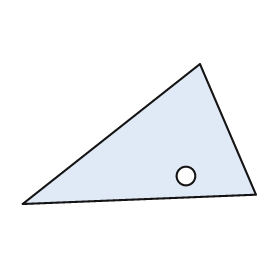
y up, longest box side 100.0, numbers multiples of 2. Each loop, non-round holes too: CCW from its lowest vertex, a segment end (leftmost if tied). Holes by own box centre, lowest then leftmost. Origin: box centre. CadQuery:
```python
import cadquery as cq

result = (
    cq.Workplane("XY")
    .moveTo(-50.0, -30.0)
    .lineTo(50.0, -26.0)
    .lineTo(26.0, 30.0)
    .close()
    .moveTo(20.0, -18.0)
    .circle(4.0)
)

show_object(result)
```